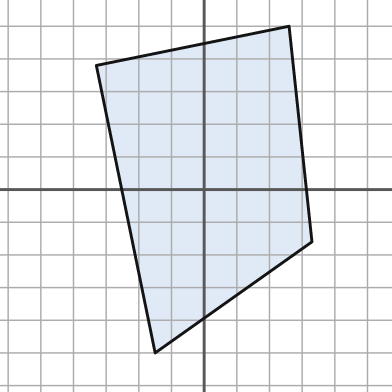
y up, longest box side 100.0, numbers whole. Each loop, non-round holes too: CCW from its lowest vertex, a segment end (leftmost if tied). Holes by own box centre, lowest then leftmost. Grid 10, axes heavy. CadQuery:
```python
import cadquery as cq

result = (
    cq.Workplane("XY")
    .moveTo(-15.0, -50.0)
    .lineTo(33.0, -16.0)
    .lineTo(26.0, 50.0)
    .lineTo(-33.0, 38.0)
    .close()
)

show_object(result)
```